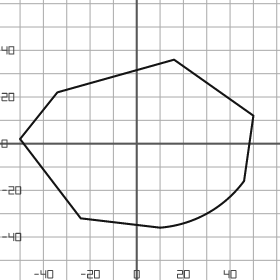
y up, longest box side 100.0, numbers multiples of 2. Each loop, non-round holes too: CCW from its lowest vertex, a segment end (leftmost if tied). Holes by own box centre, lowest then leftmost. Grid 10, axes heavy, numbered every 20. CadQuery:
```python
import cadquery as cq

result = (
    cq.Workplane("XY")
    .moveTo(10.0, -36.0)
    .threePointArc((30.0, -30.0), (46.0, -16.0))
    .lineTo(50.0, 12.0)
    .lineTo(16.0, 36.0)
    .lineTo(-34.0, 22.0)
    .lineTo(-50.0, 2.0)
    .lineTo(-24.0, -32.0)
    .close()
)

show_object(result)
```